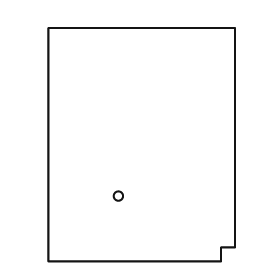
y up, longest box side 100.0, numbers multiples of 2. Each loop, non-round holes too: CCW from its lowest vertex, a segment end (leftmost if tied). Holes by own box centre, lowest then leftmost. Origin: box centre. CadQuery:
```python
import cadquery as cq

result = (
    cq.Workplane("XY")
    .moveTo(-40.0, -50.0)
    .lineTo(34.0, -50.0)
    .lineTo(34.0, -44.0)
    .lineTo(40.0, -44.0)
    .lineTo(40.0, 50.0)
    .lineTo(-40.0, 50.0)
    .close()
    .moveTo(-10.0, -22.0)
    .circle(2.0)
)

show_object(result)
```